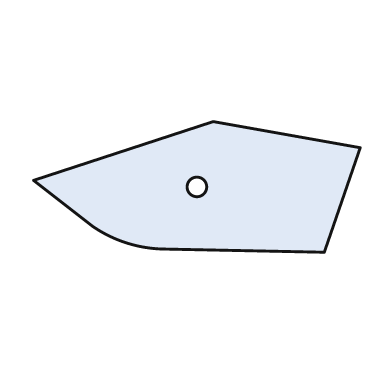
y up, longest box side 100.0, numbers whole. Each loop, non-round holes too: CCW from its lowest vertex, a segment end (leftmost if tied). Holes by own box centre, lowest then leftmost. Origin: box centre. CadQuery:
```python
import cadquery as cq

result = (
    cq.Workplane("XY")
    .moveTo(39.0, -20.0)
    .lineTo(50.0, 12.0)
    .lineTo(5.0, 20.0)
    .lineTo(-50.0, 2.0)
    .lineTo(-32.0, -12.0)
    .threePointArc((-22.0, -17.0), (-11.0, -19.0))
    .close()
    .moveTo(0.0, 0.0)
    .circle(3.0)
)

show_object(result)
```